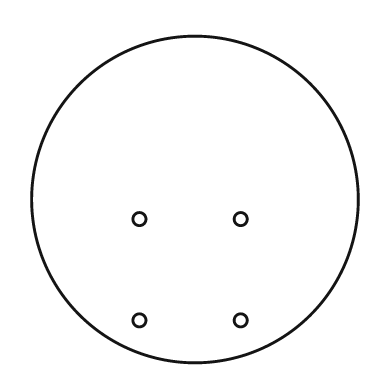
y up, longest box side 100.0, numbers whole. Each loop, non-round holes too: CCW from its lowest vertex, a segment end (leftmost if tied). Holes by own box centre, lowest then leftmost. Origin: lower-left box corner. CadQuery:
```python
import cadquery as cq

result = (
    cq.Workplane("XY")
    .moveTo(50.0, 50.0)
    .circle(50.0)
    .moveTo(33.0, 13.0)
    .circle(2.0)
    .moveTo(64.0, 13.0)
    .circle(2.0)
    .moveTo(33.0, 44.0)
    .circle(2.0)
    .moveTo(64.0, 44.0)
    .circle(2.0)
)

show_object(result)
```